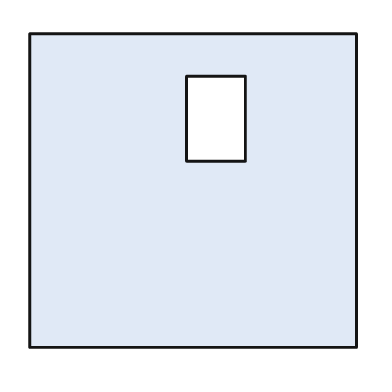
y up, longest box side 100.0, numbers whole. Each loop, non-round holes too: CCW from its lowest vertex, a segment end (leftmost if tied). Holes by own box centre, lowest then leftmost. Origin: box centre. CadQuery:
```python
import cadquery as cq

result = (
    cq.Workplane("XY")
    .moveTo(-50.0, -48.0)
    .lineTo(50.0, -48.0)
    .lineTo(50.0, 48.0)
    .lineTo(-50.0, 48.0)
    .close()
    .moveTo(-2.0, 9.0)
    .lineTo(16.0, 9.0)
    .lineTo(16.0, 35.0)
    .lineTo(-2.0, 35.0)
    .close()
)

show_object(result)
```